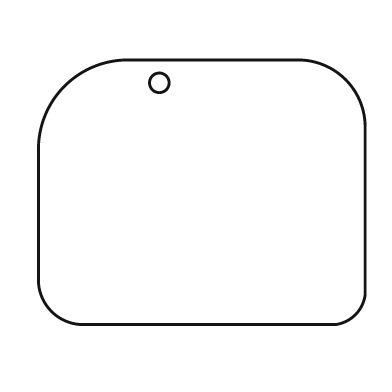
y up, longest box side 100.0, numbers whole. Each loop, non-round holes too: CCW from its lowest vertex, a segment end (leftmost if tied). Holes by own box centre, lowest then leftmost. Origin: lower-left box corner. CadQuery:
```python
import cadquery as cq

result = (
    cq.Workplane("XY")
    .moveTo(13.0, 0.0)
    .lineTo(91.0, 0.0)
    .threePointArc((97.0, 3.0), (100.0, 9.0))
    .lineTo(100.0, 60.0)
    .threePointArc((94.0, 75.0), (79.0, 81.0))
    .lineTo(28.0, 81.0)
    .threePointArc((8.0, 73.0), (0.0, 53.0))
    .lineTo(0.0, 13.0)
    .threePointArc((4.0, 4.0), (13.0, 0.0))
    .close()
    .moveTo(37.0, 74.0)
    .circle(3.0)
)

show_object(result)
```